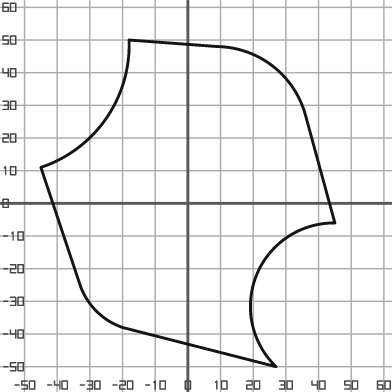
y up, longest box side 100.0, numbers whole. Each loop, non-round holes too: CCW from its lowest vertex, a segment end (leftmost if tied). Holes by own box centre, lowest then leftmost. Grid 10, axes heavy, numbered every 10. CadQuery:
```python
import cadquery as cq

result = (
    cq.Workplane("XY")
    .moveTo(27.0, -50.0)
    .threePointArc((21.0, -22.0), (45.0, -6.0))
    .lineTo(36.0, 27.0)
    .threePointArc((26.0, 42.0), (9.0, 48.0))
    .lineTo(-18.0, 50.0)
    .threePointArc((-25.0, 26.0), (-45.0, 11.0))
    .lineTo(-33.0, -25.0)
    .threePointArc((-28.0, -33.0), (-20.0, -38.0))
    .close()
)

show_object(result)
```